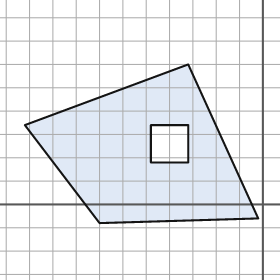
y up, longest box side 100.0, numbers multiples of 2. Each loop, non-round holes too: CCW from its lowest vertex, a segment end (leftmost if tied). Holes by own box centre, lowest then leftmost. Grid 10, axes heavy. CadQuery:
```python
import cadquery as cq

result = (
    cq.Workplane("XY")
    .moveTo(-70.0, -8.0)
    .lineTo(-2.0, -6.0)
    .lineTo(-32.0, 60.0)
    .lineTo(-102.0, 34.0)
    .close()
    .moveTo(-48.0, 18.0)
    .lineTo(-32.0, 18.0)
    .lineTo(-32.0, 34.0)
    .lineTo(-48.0, 34.0)
    .close()
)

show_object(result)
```